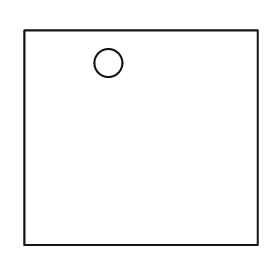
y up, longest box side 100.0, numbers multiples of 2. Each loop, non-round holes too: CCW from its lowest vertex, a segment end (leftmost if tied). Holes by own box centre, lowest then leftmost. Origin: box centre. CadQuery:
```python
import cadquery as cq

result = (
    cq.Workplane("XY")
    .moveTo(-50.0, -46.0)
    .lineTo(50.0, -46.0)
    .lineTo(50.0, 46.0)
    .lineTo(-50.0, 46.0)
    .close()
    .moveTo(-14.0, 32.0)
    .circle(6.0)
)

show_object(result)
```